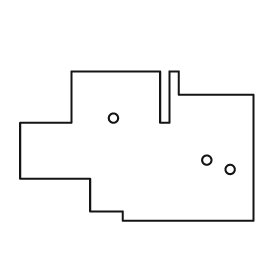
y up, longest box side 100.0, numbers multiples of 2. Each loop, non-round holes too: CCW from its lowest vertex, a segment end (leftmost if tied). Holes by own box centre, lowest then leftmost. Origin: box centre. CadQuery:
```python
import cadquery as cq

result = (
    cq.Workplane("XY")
    .moveTo(-6.0, -32.0)
    .lineTo(50.0, -32.0)
    .lineTo(50.0, 22.0)
    .lineTo(18.0, 22.0)
    .lineTo(18.0, 32.0)
    .lineTo(14.0, 32.0)
    .lineTo(14.0, 10.0)
    .lineTo(10.0, 10.0)
    .lineTo(10.0, 32.0)
    .lineTo(-28.0, 32.0)
    .lineTo(-28.0, 10.0)
    .lineTo(-50.0, 10.0)
    .lineTo(-50.0, -14.0)
    .lineTo(-20.0, -14.0)
    .lineTo(-20.0, -28.0)
    .lineTo(-6.0, -28.0)
    .close()
    .moveTo(40.0, -10.0)
    .circle(2.0)
    .moveTo(30.0, -6.0)
    .circle(2.0)
    .moveTo(-10.0, 12.0)
    .circle(2.0)
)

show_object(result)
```